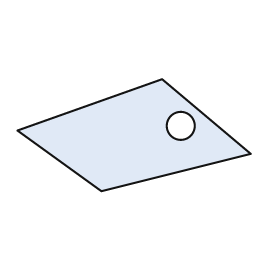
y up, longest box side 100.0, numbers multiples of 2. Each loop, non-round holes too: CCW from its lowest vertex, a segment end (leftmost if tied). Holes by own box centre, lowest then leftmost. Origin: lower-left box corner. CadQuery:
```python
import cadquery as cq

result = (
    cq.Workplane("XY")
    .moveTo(36.0, 0.0)
    .lineTo(100.0, 16.0)
    .lineTo(62.0, 48.0)
    .lineTo(0.0, 26.0)
    .close()
    .moveTo(70.0, 28.0)
    .circle(6.0)
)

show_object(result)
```